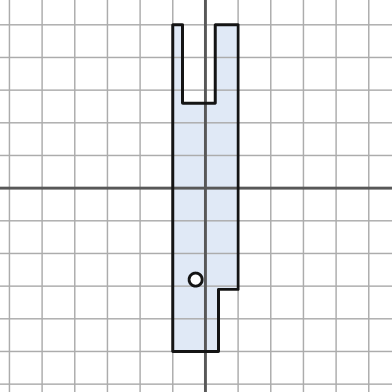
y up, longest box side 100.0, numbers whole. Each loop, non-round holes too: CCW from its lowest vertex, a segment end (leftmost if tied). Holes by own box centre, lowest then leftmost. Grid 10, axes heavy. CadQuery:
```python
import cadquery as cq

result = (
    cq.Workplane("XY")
    .moveTo(-10.0, -50.0)
    .lineTo(4.0, -50.0)
    .lineTo(4.0, -31.0)
    .lineTo(10.0, -31.0)
    .lineTo(10.0, 50.0)
    .lineTo(3.0, 50.0)
    .lineTo(3.0, 26.0)
    .lineTo(-7.0, 26.0)
    .lineTo(-7.0, 50.0)
    .lineTo(-10.0, 50.0)
    .close()
    .moveTo(-3.0, -28.0)
    .circle(2.0)
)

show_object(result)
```